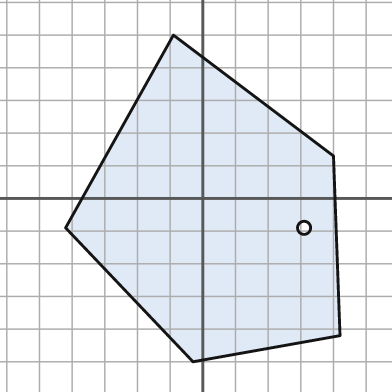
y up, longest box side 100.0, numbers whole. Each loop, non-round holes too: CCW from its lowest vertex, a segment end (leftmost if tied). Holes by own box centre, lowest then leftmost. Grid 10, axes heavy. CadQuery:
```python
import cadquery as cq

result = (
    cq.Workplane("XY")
    .moveTo(-3.0, -50.0)
    .lineTo(42.0, -42.0)
    .lineTo(40.0, 13.0)
    .lineTo(-9.0, 50.0)
    .lineTo(-42.0, -9.0)
    .close()
    .moveTo(31.0, -9.0)
    .circle(2.0)
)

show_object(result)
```